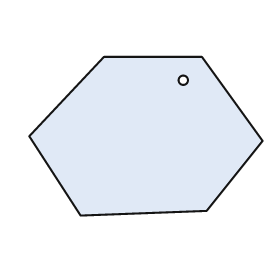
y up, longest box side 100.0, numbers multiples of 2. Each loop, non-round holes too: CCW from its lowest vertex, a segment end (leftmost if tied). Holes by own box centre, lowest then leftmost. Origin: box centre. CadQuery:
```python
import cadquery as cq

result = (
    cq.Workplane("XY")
    .moveTo(-28.0, -34.0)
    .lineTo(26.0, -32.0)
    .lineTo(50.0, -2.0)
    .lineTo(24.0, 34.0)
    .lineTo(-18.0, 34.0)
    .lineTo(-50.0, 0.0)
    .close()
    .moveTo(16.0, 24.0)
    .circle(2.0)
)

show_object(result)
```